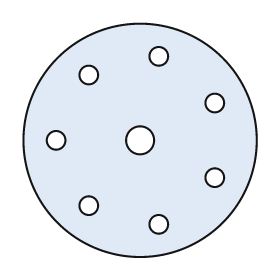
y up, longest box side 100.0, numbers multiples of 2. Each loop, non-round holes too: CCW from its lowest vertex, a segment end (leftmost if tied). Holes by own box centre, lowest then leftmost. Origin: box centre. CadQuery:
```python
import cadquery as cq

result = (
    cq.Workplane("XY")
    .moveTo(0.0, 0.0)
    .circle(50.0)
    .moveTo(8.0, -36.0)
    .circle(4.0)
    .moveTo(-22.0, -28.0)
    .circle(4.0)
    .moveTo(32.0, -16.0)
    .circle(4.0)
    .moveTo(-36.0, 0.0)
    .circle(4.0)
    .moveTo(0.0, 0.0)
    .circle(6.0)
    .moveTo(32.0, 16.0)
    .circle(4.0)
    .moveTo(-22.0, 28.0)
    .circle(4.0)
    .moveTo(8.0, 36.0)
    .circle(4.0)
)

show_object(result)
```